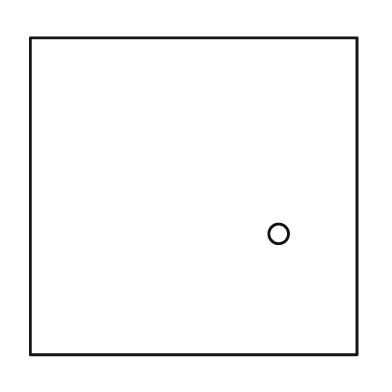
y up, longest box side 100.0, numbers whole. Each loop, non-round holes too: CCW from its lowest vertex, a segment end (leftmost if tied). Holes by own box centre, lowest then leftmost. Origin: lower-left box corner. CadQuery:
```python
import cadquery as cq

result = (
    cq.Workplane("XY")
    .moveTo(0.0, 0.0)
    .lineTo(100.0, 0.0)
    .lineTo(100.0, 97.0)
    .lineTo(0.0, 97.0)
    .close()
    .moveTo(76.0, 37.0)
    .circle(3.0)
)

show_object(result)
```